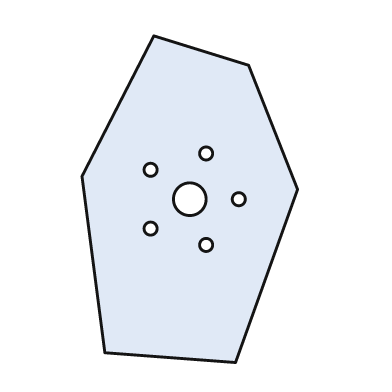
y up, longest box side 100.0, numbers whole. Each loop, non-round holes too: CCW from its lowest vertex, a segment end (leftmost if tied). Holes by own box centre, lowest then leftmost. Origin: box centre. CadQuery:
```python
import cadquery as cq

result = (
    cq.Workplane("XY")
    .moveTo(14.0, -50.0)
    .lineTo(33.0, 3.0)
    .lineTo(18.0, 41.0)
    .lineTo(-11.0, 50.0)
    .lineTo(-33.0, 7.0)
    .lineTo(-26.0, -47.0)
    .close()
    .moveTo(5.0, -14.0)
    .circle(2.0)
    .moveTo(-12.0, -9.0)
    .circle(2.0)
    .moveTo(0.0, 0.0)
    .circle(5.0)
    .moveTo(15.0, 0.0)
    .circle(2.0)
    .moveTo(-12.0, 9.0)
    .circle(2.0)
    .moveTo(5.0, 14.0)
    .circle(2.0)
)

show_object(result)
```